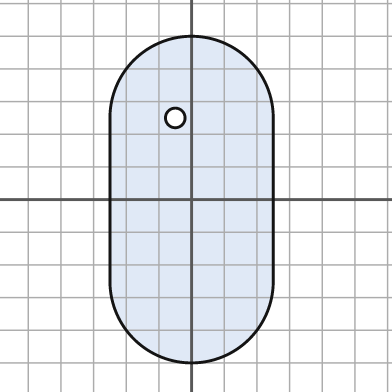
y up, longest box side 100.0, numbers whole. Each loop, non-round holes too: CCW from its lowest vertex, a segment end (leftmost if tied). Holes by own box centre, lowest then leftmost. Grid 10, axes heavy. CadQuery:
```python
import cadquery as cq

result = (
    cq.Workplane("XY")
    .moveTo(-25.0, -25.0)
    .threePointArc((0.0, -50.0), (25.0, -25.0))
    .lineTo(25.0, 25.0)
    .threePointArc((0.0, 50.0), (-25.0, 25.0))
    .close()
    .moveTo(-5.0, 25.0)
    .circle(3.0)
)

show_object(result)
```